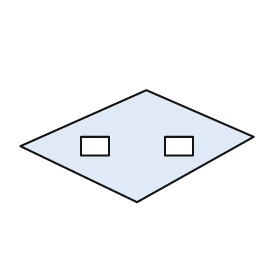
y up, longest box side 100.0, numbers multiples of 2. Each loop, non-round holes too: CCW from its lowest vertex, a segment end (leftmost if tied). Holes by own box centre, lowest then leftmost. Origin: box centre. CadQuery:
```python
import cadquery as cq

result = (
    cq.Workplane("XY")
    .moveTo(0.0, -24.0)
    .lineTo(50.0, 4.0)
    .lineTo(4.0, 24.0)
    .lineTo(-50.0, 0.0)
    .close()
    .moveTo(-24.0, -4.0)
    .lineTo(-12.0, -4.0)
    .lineTo(-12.0, 4.0)
    .lineTo(-24.0, 4.0)
    .close()
    .moveTo(12.0, -4.0)
    .lineTo(24.0, -4.0)
    .lineTo(24.0, 4.0)
    .lineTo(12.0, 4.0)
    .close()
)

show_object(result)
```